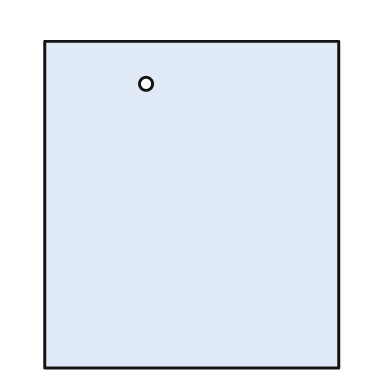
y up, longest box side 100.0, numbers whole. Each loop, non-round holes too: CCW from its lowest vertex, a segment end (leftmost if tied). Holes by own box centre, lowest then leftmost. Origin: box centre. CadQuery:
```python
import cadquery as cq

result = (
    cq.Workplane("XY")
    .moveTo(-45.0, -50.0)
    .lineTo(45.0, -50.0)
    .lineTo(45.0, 50.0)
    .lineTo(-45.0, 50.0)
    .close()
    .moveTo(-14.0, 37.0)
    .circle(2.0)
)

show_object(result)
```